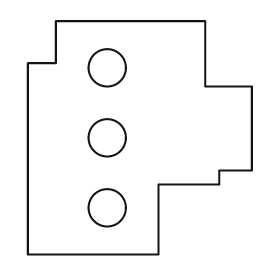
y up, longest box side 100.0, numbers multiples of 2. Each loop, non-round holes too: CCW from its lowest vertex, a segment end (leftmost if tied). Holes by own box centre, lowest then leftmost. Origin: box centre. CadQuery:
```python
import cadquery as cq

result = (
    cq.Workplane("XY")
    .moveTo(-48.0, -50.0)
    .lineTo(8.0, -50.0)
    .lineTo(8.0, -20.0)
    .lineTo(34.0, -20.0)
    .lineTo(34.0, -14.0)
    .lineTo(48.0, -14.0)
    .lineTo(48.0, 22.0)
    .lineTo(28.0, 22.0)
    .lineTo(28.0, 50.0)
    .lineTo(-36.0, 50.0)
    .lineTo(-36.0, 32.0)
    .lineTo(-48.0, 32.0)
    .close()
    .moveTo(-14.0, -30.0)
    .circle(8.0)
    .moveTo(-14.0, 0.0)
    .circle(8.0)
    .moveTo(-14.0, 30.0)
    .circle(8.0)
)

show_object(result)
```